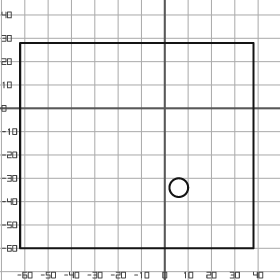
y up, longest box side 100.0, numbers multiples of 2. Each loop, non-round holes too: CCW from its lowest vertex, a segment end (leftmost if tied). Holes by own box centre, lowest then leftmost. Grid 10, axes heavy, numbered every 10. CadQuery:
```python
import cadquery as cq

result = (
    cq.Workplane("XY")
    .moveTo(-62.0, -60.0)
    .lineTo(38.0, -60.0)
    .lineTo(38.0, 28.0)
    .lineTo(-62.0, 28.0)
    .close()
    .moveTo(6.0, -34.0)
    .circle(4.0)
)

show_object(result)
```